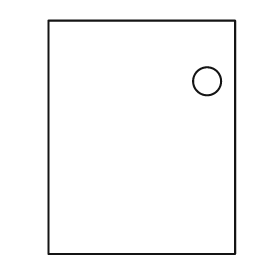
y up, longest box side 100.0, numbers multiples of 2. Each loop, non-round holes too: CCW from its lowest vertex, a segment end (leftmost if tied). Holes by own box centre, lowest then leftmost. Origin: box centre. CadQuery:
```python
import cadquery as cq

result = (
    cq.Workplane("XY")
    .moveTo(-40.0, -50.0)
    .lineTo(40.0, -50.0)
    .lineTo(40.0, 50.0)
    .lineTo(-40.0, 50.0)
    .close()
    .moveTo(28.0, 24.0)
    .circle(6.0)
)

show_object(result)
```